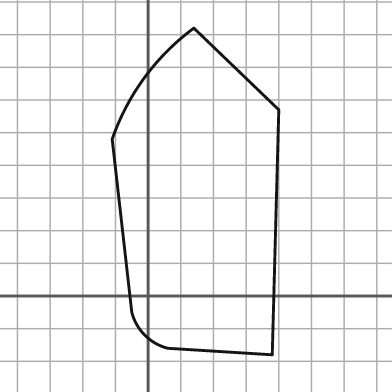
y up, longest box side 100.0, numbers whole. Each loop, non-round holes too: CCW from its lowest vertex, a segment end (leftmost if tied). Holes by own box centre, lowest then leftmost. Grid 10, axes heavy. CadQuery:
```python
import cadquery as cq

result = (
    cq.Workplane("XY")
    .moveTo(38.0, -18.0)
    .lineTo(40.0, 57.0)
    .lineTo(14.0, 82.0)
    .threePointArc((-1.0, 67.0), (-11.0, 48.0))
    .lineTo(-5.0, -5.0)
    .threePointArc((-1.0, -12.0), (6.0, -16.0))
    .close()
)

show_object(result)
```